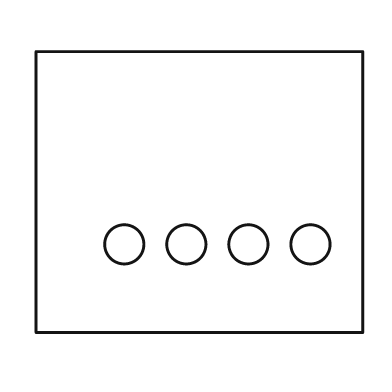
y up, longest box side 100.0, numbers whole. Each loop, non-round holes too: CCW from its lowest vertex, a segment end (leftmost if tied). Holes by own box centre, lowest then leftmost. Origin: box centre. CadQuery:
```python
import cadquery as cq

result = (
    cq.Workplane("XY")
    .moveTo(-50.0, -43.0)
    .lineTo(50.0, -43.0)
    .lineTo(50.0, 43.0)
    .lineTo(-50.0, 43.0)
    .close()
    .moveTo(-23.0, -16.0)
    .circle(6.0)
    .moveTo(-4.0, -16.0)
    .circle(6.0)
    .moveTo(15.0, -16.0)
    .circle(6.0)
    .moveTo(34.0, -16.0)
    .circle(6.0)
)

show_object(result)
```